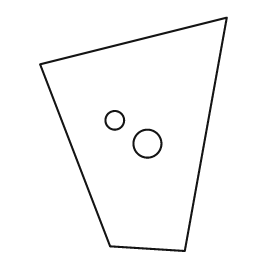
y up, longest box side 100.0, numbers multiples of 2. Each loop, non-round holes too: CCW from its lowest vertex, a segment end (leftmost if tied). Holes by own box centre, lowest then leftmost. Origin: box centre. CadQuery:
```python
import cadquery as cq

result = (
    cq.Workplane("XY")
    .moveTo(22.0, -50.0)
    .lineTo(40.0, 50.0)
    .lineTo(-40.0, 30.0)
    .lineTo(-10.0, -48.0)
    .close()
    .moveTo(6.0, -4.0)
    .circle(6.0)
    .moveTo(-8.0, 6.0)
    .circle(4.0)
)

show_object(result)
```